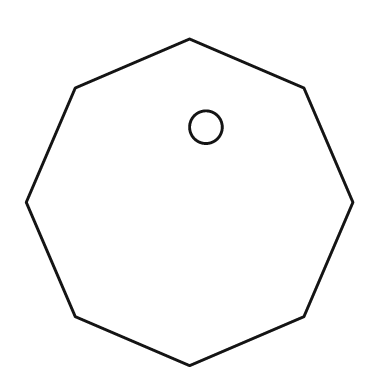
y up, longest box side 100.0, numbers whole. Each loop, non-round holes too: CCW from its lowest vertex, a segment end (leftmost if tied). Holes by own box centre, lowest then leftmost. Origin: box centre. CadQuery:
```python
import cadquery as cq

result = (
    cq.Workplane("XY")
    .moveTo(0.0, -50.0)
    .lineTo(35.0, -35.0)
    .lineTo(50.0, 0.0)
    .lineTo(35.0, 35.0)
    .lineTo(0.0, 50.0)
    .lineTo(-35.0, 35.0)
    .lineTo(-50.0, 0.0)
    .lineTo(-35.0, -35.0)
    .close()
    .moveTo(5.0, 23.0)
    .circle(5.0)
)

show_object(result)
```